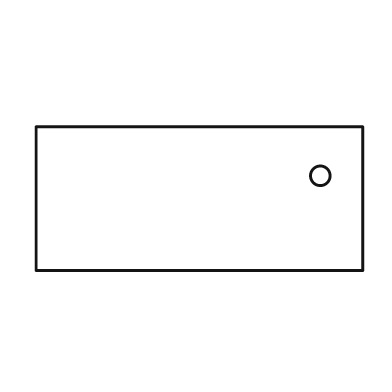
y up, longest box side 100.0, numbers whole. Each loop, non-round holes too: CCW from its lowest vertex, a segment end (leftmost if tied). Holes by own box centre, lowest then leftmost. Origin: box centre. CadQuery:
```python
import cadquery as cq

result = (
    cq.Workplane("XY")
    .moveTo(-50.0, -22.0)
    .lineTo(50.0, -22.0)
    .lineTo(50.0, 22.0)
    .lineTo(-50.0, 22.0)
    .close()
    .moveTo(37.0, 7.0)
    .circle(3.0)
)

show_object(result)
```